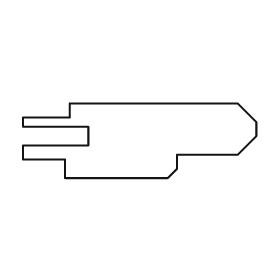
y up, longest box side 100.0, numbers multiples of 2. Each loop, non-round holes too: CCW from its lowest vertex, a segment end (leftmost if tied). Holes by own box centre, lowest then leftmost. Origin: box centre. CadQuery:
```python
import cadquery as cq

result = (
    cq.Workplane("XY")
    .moveTo(-32.0, -16.0)
    .lineTo(12.0, -16.0)
    .lineTo(16.0, -12.0)
    .lineTo(16.0, -6.0)
    .lineTo(42.0, -6.0)
    .lineTo(50.0, 2.0)
    .lineTo(50.0, 8.0)
    .lineTo(42.0, 16.0)
    .lineTo(-30.0, 16.0)
    .lineTo(-30.0, 10.0)
    .lineTo(-50.0, 10.0)
    .lineTo(-50.0, 6.0)
    .lineTo(-22.0, 6.0)
    .lineTo(-22.0, -2.0)
    .lineTo(-50.0, -2.0)
    .lineTo(-50.0, -8.0)
    .lineTo(-32.0, -8.0)
    .close()
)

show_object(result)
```